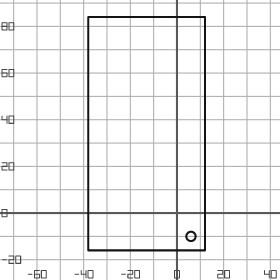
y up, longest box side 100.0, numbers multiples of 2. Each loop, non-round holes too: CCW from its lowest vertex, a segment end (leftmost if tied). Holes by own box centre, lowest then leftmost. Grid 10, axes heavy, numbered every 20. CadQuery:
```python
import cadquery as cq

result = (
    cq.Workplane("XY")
    .moveTo(-38.0, -16.0)
    .lineTo(12.0, -16.0)
    .lineTo(12.0, 84.0)
    .lineTo(-38.0, 84.0)
    .close()
    .moveTo(6.0, -10.0)
    .circle(2.0)
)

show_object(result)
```